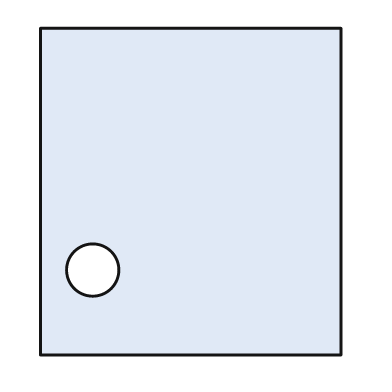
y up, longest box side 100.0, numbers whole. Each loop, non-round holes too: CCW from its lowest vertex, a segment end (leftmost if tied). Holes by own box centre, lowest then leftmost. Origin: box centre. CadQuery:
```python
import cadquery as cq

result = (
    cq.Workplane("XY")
    .moveTo(-46.0, -50.0)
    .lineTo(46.0, -50.0)
    .lineTo(46.0, 50.0)
    .lineTo(-46.0, 50.0)
    .close()
    .moveTo(-30.0, -24.0)
    .circle(8.0)
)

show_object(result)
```